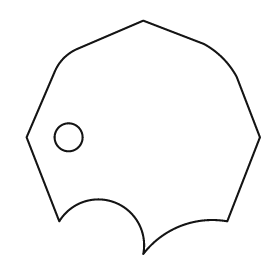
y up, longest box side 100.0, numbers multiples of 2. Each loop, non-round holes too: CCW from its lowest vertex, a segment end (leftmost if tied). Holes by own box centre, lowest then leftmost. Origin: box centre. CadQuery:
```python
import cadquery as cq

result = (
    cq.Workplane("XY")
    .moveTo(0.0, -50.0)
    .threePointArc((16.0, -38.0), (36.0, -36.0))
    .lineTo(50.0, 0.0)
    .lineTo(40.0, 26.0)
    .threePointArc((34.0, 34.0), (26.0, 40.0))
    .lineTo(0.0, 50.0)
    .lineTo(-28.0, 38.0)
    .threePointArc((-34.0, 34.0), (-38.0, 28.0))
    .lineTo(-50.0, 0.0)
    .lineTo(-36.0, -36.0)
    .threePointArc((-12.0, -28.0), (0.0, -50.0))
    .close()
    .moveTo(-32.0, 0.0)
    .circle(6.0)
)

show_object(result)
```